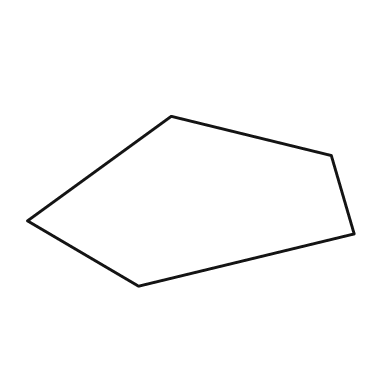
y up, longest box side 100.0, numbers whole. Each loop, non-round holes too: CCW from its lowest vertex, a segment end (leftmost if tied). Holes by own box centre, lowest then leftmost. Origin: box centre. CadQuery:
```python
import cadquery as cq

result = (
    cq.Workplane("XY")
    .moveTo(-16.0, -26.0)
    .lineTo(50.0, -10.0)
    .lineTo(43.0, 14.0)
    .lineTo(-6.0, 26.0)
    .lineTo(-50.0, -6.0)
    .close()
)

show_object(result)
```